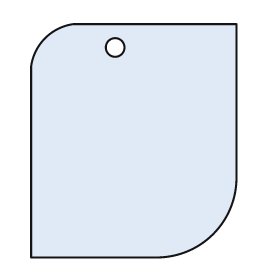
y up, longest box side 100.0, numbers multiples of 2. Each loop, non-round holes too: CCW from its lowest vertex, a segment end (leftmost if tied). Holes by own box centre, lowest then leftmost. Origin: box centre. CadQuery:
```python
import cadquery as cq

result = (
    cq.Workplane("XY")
    .moveTo(-44.0, -50.0)
    .lineTo(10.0, -50.0)
    .threePointArc((34.0, -40.0), (44.0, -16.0))
    .lineTo(44.0, 50.0)
    .lineTo(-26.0, 50.0)
    .threePointArc((-38.0, 44.0), (-44.0, 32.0))
    .close()
    .moveTo(-8.0, 40.0)
    .circle(4.0)
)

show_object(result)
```